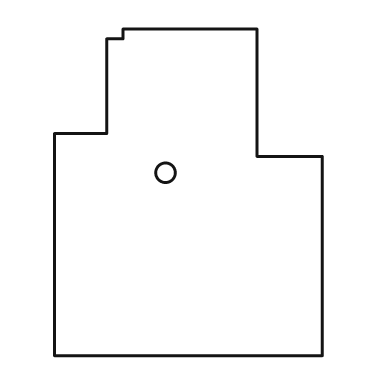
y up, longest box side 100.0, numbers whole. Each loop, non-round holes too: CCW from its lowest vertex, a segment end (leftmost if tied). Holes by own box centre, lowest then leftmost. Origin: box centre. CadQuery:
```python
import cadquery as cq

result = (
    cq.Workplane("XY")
    .moveTo(-41.0, -50.0)
    .lineTo(41.0, -50.0)
    .lineTo(41.0, 11.0)
    .lineTo(21.0, 11.0)
    .lineTo(21.0, 50.0)
    .lineTo(-20.0, 50.0)
    .lineTo(-20.0, 47.0)
    .lineTo(-25.0, 47.0)
    .lineTo(-25.0, 18.0)
    .lineTo(-41.0, 18.0)
    .close()
    .moveTo(-7.0, 6.0)
    .circle(3.0)
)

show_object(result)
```